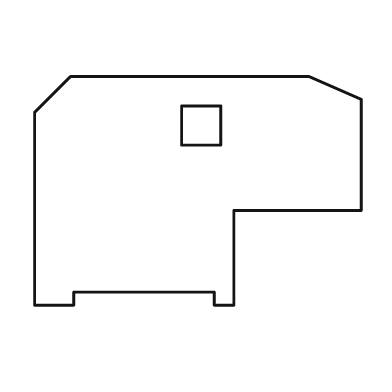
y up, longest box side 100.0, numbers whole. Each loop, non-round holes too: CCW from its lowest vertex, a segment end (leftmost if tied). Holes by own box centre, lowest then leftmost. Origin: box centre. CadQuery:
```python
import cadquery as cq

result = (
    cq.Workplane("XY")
    .moveTo(-50.0, -35.0)
    .lineTo(-38.0, -35.0)
    .lineTo(-38.0, -31.0)
    .lineTo(5.0, -31.0)
    .lineTo(5.0, -35.0)
    .lineTo(11.0, -35.0)
    .lineTo(11.0, -6.0)
    .lineTo(50.0, -6.0)
    .lineTo(50.0, 28.0)
    .lineTo(34.0, 35.0)
    .lineTo(-39.0, 35.0)
    .lineTo(-50.0, 24.0)
    .close()
    .moveTo(-5.0, 14.0)
    .lineTo(7.0, 14.0)
    .lineTo(7.0, 26.0)
    .lineTo(-5.0, 26.0)
    .close()
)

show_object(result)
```